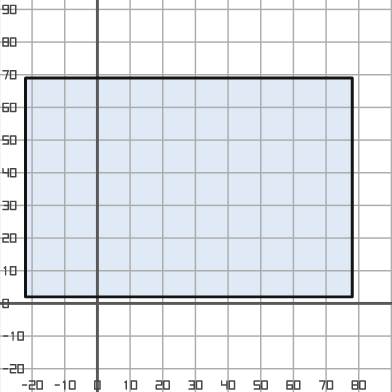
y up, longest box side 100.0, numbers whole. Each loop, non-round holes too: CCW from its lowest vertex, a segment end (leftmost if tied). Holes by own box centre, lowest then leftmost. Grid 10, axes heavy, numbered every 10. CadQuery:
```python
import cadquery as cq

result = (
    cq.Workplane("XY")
    .moveTo(-22.0, 2.0)
    .lineTo(78.0, 2.0)
    .lineTo(78.0, 69.0)
    .lineTo(-22.0, 69.0)
    .close()
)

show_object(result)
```